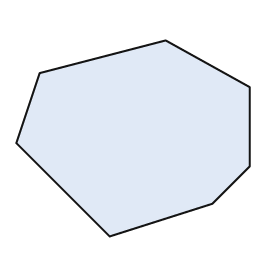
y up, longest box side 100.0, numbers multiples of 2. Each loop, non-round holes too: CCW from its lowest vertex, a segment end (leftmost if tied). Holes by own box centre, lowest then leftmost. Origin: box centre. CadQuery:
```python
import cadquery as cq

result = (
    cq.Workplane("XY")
    .moveTo(-10.0, -42.0)
    .lineTo(34.0, -28.0)
    .lineTo(50.0, -12.0)
    .lineTo(50.0, 22.0)
    .lineTo(14.0, 42.0)
    .lineTo(-40.0, 28.0)
    .lineTo(-50.0, -2.0)
    .close()
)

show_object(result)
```